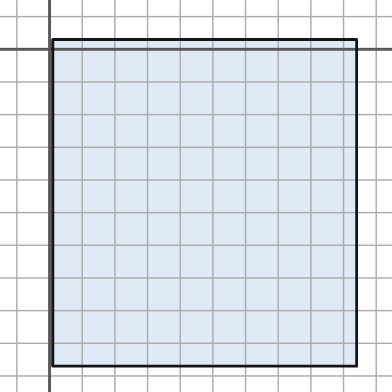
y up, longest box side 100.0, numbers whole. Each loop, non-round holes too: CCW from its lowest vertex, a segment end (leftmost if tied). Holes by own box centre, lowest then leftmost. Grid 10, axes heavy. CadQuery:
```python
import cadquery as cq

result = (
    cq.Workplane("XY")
    .moveTo(1.0, -97.0)
    .lineTo(94.0, -97.0)
    .lineTo(94.0, 3.0)
    .lineTo(1.0, 3.0)
    .close()
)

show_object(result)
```